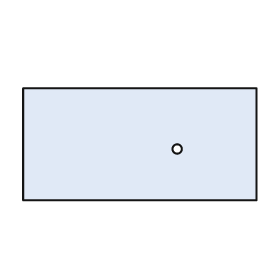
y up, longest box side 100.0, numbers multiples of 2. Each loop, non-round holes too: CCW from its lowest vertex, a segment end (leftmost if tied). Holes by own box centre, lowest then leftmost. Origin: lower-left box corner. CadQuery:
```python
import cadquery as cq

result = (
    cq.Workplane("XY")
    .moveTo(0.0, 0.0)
    .lineTo(100.0, 0.0)
    .lineTo(100.0, 48.0)
    .lineTo(0.0, 48.0)
    .close()
    .moveTo(66.0, 22.0)
    .circle(2.0)
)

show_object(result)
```